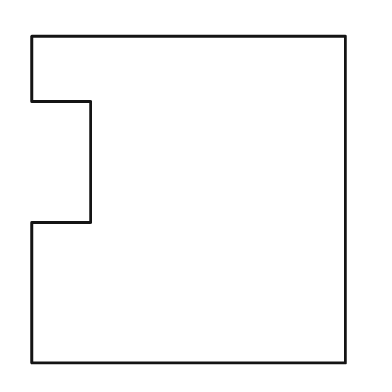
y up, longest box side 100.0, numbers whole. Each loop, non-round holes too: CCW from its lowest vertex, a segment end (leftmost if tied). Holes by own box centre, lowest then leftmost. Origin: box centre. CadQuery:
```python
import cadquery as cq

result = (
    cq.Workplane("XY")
    .moveTo(-48.0, -50.0)
    .lineTo(48.0, -50.0)
    .lineTo(48.0, 50.0)
    .lineTo(-48.0, 50.0)
    .lineTo(-48.0, 30.0)
    .lineTo(-30.0, 30.0)
    .lineTo(-30.0, -7.0)
    .lineTo(-48.0, -7.0)
    .close()
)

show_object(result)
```